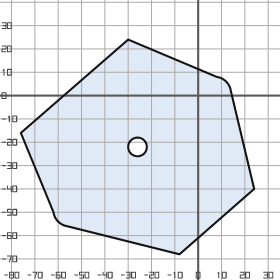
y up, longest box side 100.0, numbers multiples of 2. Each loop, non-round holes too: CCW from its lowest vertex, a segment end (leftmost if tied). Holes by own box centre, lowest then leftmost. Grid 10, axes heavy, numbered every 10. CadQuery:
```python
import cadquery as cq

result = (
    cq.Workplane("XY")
    .moveTo(-8.0, -68.0)
    .lineTo(24.0, -40.0)
    .lineTo(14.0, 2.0)
    .threePointArc((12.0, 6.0), (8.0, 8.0))
    .lineTo(-30.0, 24.0)
    .lineTo(-76.0, -16.0)
    .lineTo(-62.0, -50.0)
    .threePointArc((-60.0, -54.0), (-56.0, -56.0))
    .close()
    .moveTo(-26.0, -22.0)
    .circle(4.0)
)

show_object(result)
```